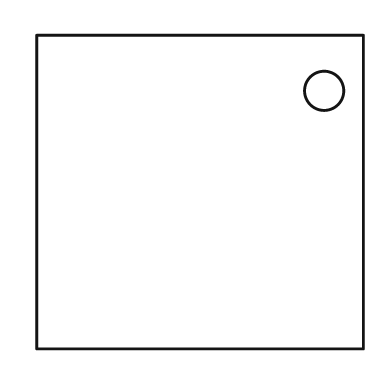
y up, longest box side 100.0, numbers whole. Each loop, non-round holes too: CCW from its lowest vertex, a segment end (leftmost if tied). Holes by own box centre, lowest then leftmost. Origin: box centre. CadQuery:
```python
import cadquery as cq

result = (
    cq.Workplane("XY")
    .moveTo(-50.0, -48.0)
    .lineTo(50.0, -48.0)
    .lineTo(50.0, 48.0)
    .lineTo(-50.0, 48.0)
    .close()
    .moveTo(38.0, 31.0)
    .circle(6.0)
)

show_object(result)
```